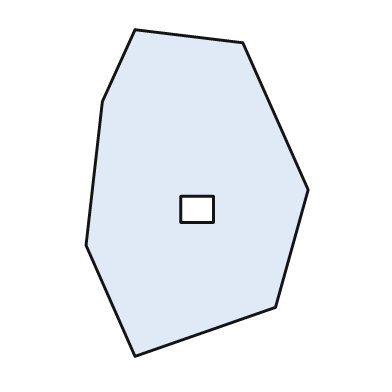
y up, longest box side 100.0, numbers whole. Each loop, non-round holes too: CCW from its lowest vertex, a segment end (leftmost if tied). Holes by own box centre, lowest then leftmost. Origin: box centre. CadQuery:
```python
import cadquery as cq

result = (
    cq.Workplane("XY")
    .moveTo(-19.0, -50.0)
    .lineTo(24.0, -35.0)
    .lineTo(34.0, 1.0)
    .lineTo(14.0, 46.0)
    .lineTo(-19.0, 50.0)
    .lineTo(-29.0, 28.0)
    .lineTo(-34.0, -16.0)
    .close()
    .moveTo(-5.0, -9.0)
    .lineTo(5.0, -9.0)
    .lineTo(5.0, -1.0)
    .lineTo(-5.0, -1.0)
    .close()
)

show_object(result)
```